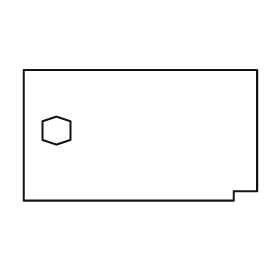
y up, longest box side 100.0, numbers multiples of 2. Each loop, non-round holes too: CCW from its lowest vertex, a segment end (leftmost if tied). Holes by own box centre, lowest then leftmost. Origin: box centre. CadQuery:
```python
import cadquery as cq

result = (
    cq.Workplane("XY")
    .moveTo(-50.0, -28.0)
    .lineTo(40.0, -28.0)
    .lineTo(40.0, -24.0)
    .lineTo(50.0, -24.0)
    .lineTo(50.0, 28.0)
    .lineTo(-50.0, 28.0)
    .close()
    .moveTo(-36.0, -4.0)
    .lineTo(-30.0, -2.0)
    .lineTo(-30.0, 6.0)
    .lineTo(-36.0, 8.0)
    .lineTo(-42.0, 6.0)
    .lineTo(-42.0, -2.0)
    .close()
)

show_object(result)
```